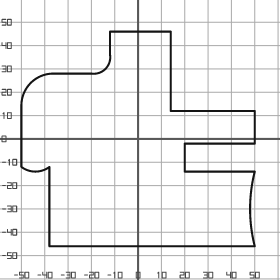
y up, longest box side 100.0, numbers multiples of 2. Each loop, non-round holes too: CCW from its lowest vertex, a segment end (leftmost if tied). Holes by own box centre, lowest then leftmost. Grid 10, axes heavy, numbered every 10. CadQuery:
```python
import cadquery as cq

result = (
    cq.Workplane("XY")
    .moveTo(-38.0, -46.0)
    .lineTo(50.0, -46.0)
    .threePointArc((48.0, -30.0), (50.0, -14.0))
    .lineTo(20.0, -14.0)
    .lineTo(20.0, -2.0)
    .lineTo(50.0, -2.0)
    .lineTo(50.0, 12.0)
    .lineTo(14.0, 12.0)
    .lineTo(14.0, 46.0)
    .lineTo(-12.0, 46.0)
    .lineTo(-12.0, 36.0)
    .threePointArc((-14.0, 30.0), (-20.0, 28.0))
    .lineTo(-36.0, 28.0)
    .threePointArc((-46.0, 24.0), (-50.0, 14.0))
    .lineTo(-50.0, -12.0)
    .threePointArc((-44.0, -14.0), (-38.0, -12.0))
    .close()
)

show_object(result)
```